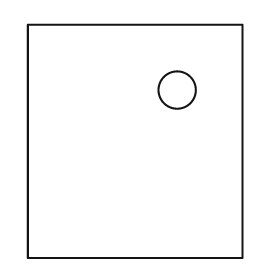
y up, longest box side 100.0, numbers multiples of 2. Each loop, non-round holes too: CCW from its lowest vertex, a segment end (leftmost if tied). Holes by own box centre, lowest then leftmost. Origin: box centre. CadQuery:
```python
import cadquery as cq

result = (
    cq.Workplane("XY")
    .moveTo(-46.0, -50.0)
    .lineTo(46.0, -50.0)
    .lineTo(46.0, 50.0)
    .lineTo(-46.0, 50.0)
    .close()
    .moveTo(18.0, 22.0)
    .circle(8.0)
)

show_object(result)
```